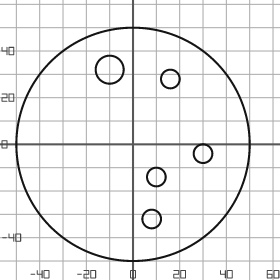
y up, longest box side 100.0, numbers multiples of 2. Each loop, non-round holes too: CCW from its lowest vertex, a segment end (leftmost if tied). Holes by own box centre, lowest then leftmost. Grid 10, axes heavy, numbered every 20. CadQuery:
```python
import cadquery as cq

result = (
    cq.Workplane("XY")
    .moveTo(0.0, 0.0)
    .circle(50.0)
    .moveTo(8.0, -32.0)
    .circle(4.0)
    .moveTo(10.0, -14.0)
    .circle(4.0)
    .moveTo(30.0, -4.0)
    .circle(4.0)
    .moveTo(16.0, 28.0)
    .circle(4.0)
    .moveTo(-10.0, 32.0)
    .circle(6.0)
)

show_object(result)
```